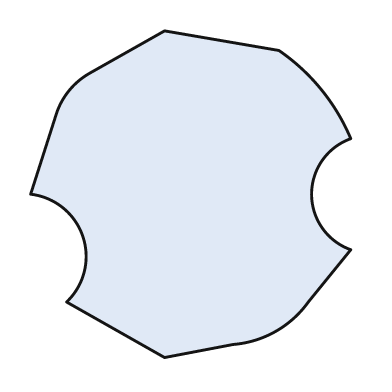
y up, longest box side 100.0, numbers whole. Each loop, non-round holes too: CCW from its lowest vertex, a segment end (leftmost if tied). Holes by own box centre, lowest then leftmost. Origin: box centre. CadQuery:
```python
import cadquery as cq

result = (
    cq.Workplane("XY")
    .moveTo(-8.0, -50.0)
    .lineTo(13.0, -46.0)
    .threePointArc((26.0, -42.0), (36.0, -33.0))
    .lineTo(49.0, -17.0)
    .threePointArc((37.0, 0.0), (49.0, 17.0))
    .threePointArc((40.0, 32.0), (27.0, 44.0))
    .lineTo(-8.0, 50.0)
    .lineTo(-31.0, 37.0)
    .threePointArc((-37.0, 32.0), (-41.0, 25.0))
    .lineTo(-49.0, 0.0)
    .threePointArc((-33.0, -13.0), (-38.0, -33.0))
    .close()
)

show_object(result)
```